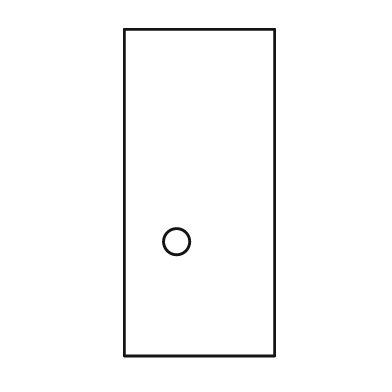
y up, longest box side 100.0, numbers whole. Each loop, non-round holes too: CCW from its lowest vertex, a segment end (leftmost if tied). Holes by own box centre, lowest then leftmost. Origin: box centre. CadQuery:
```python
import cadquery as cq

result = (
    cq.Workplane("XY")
    .moveTo(-23.0, -50.0)
    .lineTo(23.0, -50.0)
    .lineTo(23.0, 50.0)
    .lineTo(-23.0, 50.0)
    .close()
    .moveTo(-7.0, -15.0)
    .circle(4.0)
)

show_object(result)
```